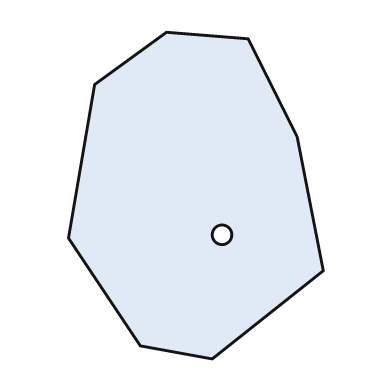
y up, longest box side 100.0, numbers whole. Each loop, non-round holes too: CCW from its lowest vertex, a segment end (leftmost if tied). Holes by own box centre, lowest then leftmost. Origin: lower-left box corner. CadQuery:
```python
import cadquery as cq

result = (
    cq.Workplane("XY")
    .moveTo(44.0, 0.0)
    .lineTo(78.0, 27.0)
    .lineTo(70.0, 68.0)
    .lineTo(55.0, 98.0)
    .lineTo(30.0, 100.0)
    .lineTo(8.0, 84.0)
    .lineTo(0.0, 37.0)
    .lineTo(22.0, 4.0)
    .close()
    .moveTo(47.0, 38.0)
    .circle(3.0)
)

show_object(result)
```